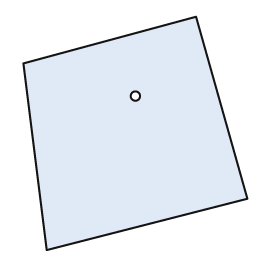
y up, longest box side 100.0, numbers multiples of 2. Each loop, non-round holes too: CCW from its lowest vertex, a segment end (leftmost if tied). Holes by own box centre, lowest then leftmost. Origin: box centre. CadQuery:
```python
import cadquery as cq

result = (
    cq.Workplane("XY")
    .moveTo(-38.0, -50.0)
    .lineTo(48.0, -28.0)
    .lineTo(26.0, 50.0)
    .lineTo(-48.0, 30.0)
    .close()
    .moveTo(0.0, 16.0)
    .circle(2.0)
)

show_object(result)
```